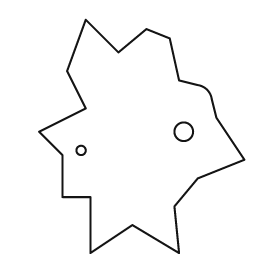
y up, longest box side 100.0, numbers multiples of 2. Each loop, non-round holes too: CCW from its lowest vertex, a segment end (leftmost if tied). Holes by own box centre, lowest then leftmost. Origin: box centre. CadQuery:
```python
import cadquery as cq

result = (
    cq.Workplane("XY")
    .moveTo(-22.0, -50.0)
    .lineTo(-4.0, -38.0)
    .lineTo(16.0, -50.0)
    .lineTo(14.0, -30.0)
    .lineTo(24.0, -18.0)
    .lineTo(44.0, -10.0)
    .lineTo(32.0, 8.0)
    .lineTo(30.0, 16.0)
    .threePointArc((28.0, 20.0), (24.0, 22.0))
    .lineTo(16.0, 24.0)
    .lineTo(12.0, 42.0)
    .lineTo(2.0, 46.0)
    .lineTo(-10.0, 36.0)
    .lineTo(-24.0, 50.0)
    .lineTo(-32.0, 28.0)
    .lineTo(-24.0, 12.0)
    .lineTo(-44.0, 2.0)
    .lineTo(-34.0, -8.0)
    .lineTo(-34.0, -26.0)
    .lineTo(-22.0, -26.0)
    .close()
    .moveTo(-26.0, -6.0)
    .circle(2.0)
    .moveTo(18.0, 2.0)
    .circle(4.0)
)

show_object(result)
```